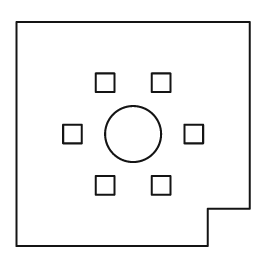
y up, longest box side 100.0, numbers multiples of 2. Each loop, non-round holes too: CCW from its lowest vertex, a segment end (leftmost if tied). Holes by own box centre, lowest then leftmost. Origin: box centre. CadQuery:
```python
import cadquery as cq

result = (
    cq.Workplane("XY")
    .moveTo(-50.0, -48.0)
    .lineTo(32.0, -48.0)
    .lineTo(32.0, -32.0)
    .lineTo(50.0, -32.0)
    .lineTo(50.0, 48.0)
    .lineTo(-50.0, 48.0)
    .close()
    .moveTo(-16.0, -26.0)
    .lineTo(-8.0, -26.0)
    .lineTo(-8.0, -18.0)
    .lineTo(-16.0, -18.0)
    .close()
    .moveTo(8.0, -26.0)
    .lineTo(16.0, -26.0)
    .lineTo(16.0, -18.0)
    .lineTo(8.0, -18.0)
    .close()
    .moveTo(-30.0, -4.0)
    .lineTo(-22.0, -4.0)
    .lineTo(-22.0, 4.0)
    .lineTo(-30.0, 4.0)
    .close()
    .moveTo(0.0, 0.0)
    .circle(12.0)
    .moveTo(22.0, -4.0)
    .lineTo(30.0, -4.0)
    .lineTo(30.0, 4.0)
    .lineTo(22.0, 4.0)
    .close()
    .moveTo(-16.0, 18.0)
    .lineTo(-8.0, 18.0)
    .lineTo(-8.0, 26.0)
    .lineTo(-16.0, 26.0)
    .close()
    .moveTo(8.0, 18.0)
    .lineTo(16.0, 18.0)
    .lineTo(16.0, 26.0)
    .lineTo(8.0, 26.0)
    .close()
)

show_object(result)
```